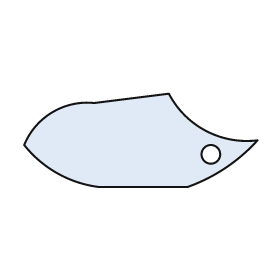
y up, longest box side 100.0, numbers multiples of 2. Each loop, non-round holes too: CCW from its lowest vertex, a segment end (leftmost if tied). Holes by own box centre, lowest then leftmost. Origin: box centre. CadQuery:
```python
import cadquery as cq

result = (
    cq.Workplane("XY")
    .moveTo(-18.0, -20.0)
    .lineTo(20.0, -20.0)
    .threePointArc((36.0, -12.0), (50.0, 0.0))
    .threePointArc((28.0, 4.0), (12.0, 20.0))
    .lineTo(-20.0, 16.0)
    .threePointArc((-38.0, 12.0), (-50.0, -2.0))
    .threePointArc((-36.0, -14.0), (-18.0, -20.0))
    .close()
    .moveTo(30.0, -6.0)
    .circle(4.0)
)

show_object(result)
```